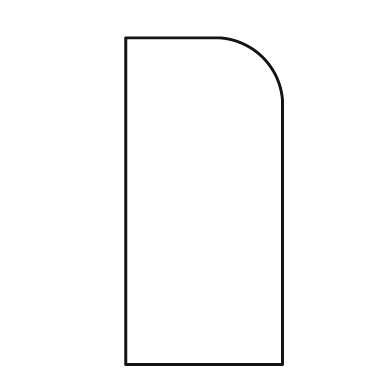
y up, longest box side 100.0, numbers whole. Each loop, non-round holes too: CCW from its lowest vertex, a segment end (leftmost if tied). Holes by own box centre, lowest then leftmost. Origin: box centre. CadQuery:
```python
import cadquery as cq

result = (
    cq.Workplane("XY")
    .moveTo(-24.0, -50.0)
    .lineTo(24.0, -50.0)
    .lineTo(24.0, 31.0)
    .threePointArc((18.0, 44.0), (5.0, 50.0))
    .lineTo(-24.0, 50.0)
    .close()
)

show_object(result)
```